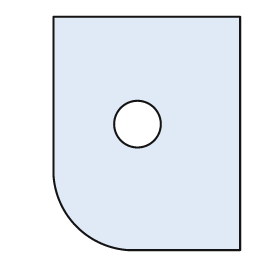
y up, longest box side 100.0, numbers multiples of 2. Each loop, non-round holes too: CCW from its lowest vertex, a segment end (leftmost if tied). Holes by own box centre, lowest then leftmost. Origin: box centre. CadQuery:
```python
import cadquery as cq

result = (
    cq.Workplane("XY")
    .moveTo(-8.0, -50.0)
    .lineTo(40.0, -50.0)
    .lineTo(40.0, 50.0)
    .lineTo(-40.0, 50.0)
    .lineTo(-40.0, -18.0)
    .threePointArc((-30.0, -40.0), (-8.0, -50.0))
    .close()
    .moveTo(-4.0, 4.0)
    .circle(10.0)
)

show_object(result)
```